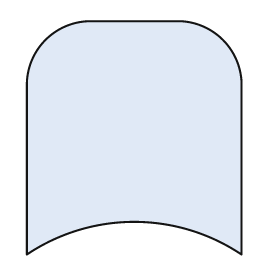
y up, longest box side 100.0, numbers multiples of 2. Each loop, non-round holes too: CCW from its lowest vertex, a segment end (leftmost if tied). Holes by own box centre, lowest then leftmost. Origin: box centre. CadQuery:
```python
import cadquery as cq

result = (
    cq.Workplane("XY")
    .moveTo(-46.0, -50.0)
    .threePointArc((0.0, -36.0), (46.0, -50.0))
    .lineTo(46.0, 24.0)
    .threePointArc((38.0, 42.0), (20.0, 50.0))
    .lineTo(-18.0, 50.0)
    .threePointArc((-38.0, 42.0), (-46.0, 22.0))
    .close()
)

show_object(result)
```